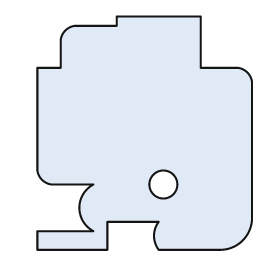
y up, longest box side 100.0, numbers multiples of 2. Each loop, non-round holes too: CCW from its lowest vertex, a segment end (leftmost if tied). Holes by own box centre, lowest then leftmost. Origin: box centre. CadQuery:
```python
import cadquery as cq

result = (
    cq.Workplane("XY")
    .moveTo(-46.0, -50.0)
    .lineTo(-16.0, -50.0)
    .lineTo(-16.0, -38.0)
    .lineTo(6.0, -38.0)
    .threePointArc((4.0, -44.0), (6.0, -50.0))
    .lineTo(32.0, -50.0)
    .threePointArc((42.0, -46.0), (46.0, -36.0))
    .lineTo(46.0, 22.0)
    .threePointArc((44.0, 26.0), (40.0, 28.0))
    .lineTo(24.0, 28.0)
    .lineTo(24.0, 50.0)
    .lineTo(-12.0, 50.0)
    .lineTo(-12.0, 46.0)
    .lineTo(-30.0, 46.0)
    .threePointArc((-34.0, 44.0), (-36.0, 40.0))
    .lineTo(-36.0, 28.0)
    .lineTo(-46.0, 28.0)
    .lineTo(-46.0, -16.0)
    .threePointArc((-44.0, -20.0), (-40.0, -22.0))
    .lineTo(-22.0, -22.0)
    .threePointArc((-28.0, -32.0), (-22.0, -42.0))
    .lineTo(-46.0, -42.0)
    .close()
    .moveTo(8.0, -22.0)
    .circle(6.0)
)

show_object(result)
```